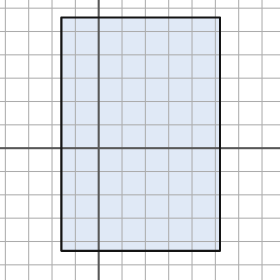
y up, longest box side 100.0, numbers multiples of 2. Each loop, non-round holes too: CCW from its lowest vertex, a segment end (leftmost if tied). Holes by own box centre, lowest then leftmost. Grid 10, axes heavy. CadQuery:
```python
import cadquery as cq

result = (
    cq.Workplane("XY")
    .moveTo(-16.0, -44.0)
    .lineTo(52.0, -44.0)
    .lineTo(52.0, 56.0)
    .lineTo(-16.0, 56.0)
    .close()
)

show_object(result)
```